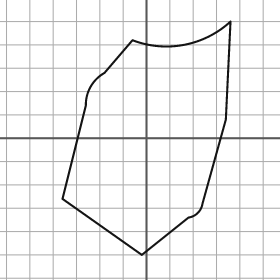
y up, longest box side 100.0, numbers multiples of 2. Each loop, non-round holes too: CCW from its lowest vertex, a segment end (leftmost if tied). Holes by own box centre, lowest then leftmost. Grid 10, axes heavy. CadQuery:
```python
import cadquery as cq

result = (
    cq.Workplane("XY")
    .moveTo(-2.0, -50.0)
    .lineTo(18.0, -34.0)
    .threePointArc((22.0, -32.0), (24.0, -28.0))
    .lineTo(34.0, 8.0)
    .lineTo(36.0, 50.0)
    .threePointArc((16.0, 40.0), (-6.0, 42.0))
    .lineTo(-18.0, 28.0)
    .threePointArc((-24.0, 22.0), (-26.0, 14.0))
    .lineTo(-36.0, -26.0)
    .close()
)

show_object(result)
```